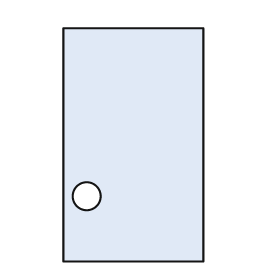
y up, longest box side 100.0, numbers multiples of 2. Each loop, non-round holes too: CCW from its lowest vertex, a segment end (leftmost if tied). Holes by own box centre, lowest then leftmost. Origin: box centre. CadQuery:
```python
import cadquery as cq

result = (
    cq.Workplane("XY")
    .moveTo(-30.0, -50.0)
    .lineTo(30.0, -50.0)
    .lineTo(30.0, 50.0)
    .lineTo(-30.0, 50.0)
    .close()
    .moveTo(-20.0, -22.0)
    .circle(6.0)
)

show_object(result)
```